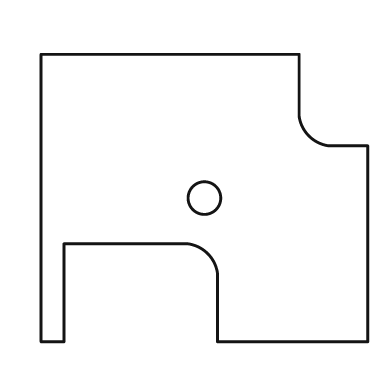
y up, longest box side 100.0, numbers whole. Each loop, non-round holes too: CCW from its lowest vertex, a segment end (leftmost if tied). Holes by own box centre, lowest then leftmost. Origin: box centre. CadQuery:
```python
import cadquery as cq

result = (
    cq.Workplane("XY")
    .moveTo(-50.0, -44.0)
    .lineTo(-43.0, -44.0)
    .lineTo(-43.0, -14.0)
    .lineTo(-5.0, -14.0)
    .threePointArc((1.0, -17.0), (4.0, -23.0))
    .lineTo(4.0, -44.0)
    .lineTo(50.0, -44.0)
    .lineTo(50.0, 16.0)
    .lineTo(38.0, 16.0)
    .threePointArc((32.0, 19.0), (29.0, 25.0))
    .lineTo(29.0, 44.0)
    .lineTo(-50.0, 44.0)
    .close()
    .moveTo(0.0, 0.0)
    .circle(5.0)
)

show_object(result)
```